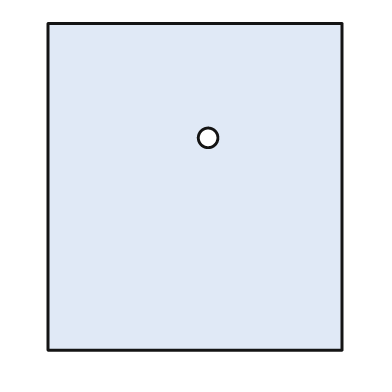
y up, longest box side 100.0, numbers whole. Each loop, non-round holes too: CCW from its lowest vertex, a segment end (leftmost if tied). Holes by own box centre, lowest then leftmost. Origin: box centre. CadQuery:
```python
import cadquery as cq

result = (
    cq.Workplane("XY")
    .moveTo(-45.0, -50.0)
    .lineTo(45.0, -50.0)
    .lineTo(45.0, 50.0)
    .lineTo(-45.0, 50.0)
    .close()
    .moveTo(4.0, 15.0)
    .circle(3.0)
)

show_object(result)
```